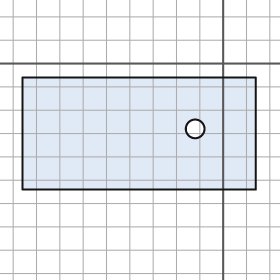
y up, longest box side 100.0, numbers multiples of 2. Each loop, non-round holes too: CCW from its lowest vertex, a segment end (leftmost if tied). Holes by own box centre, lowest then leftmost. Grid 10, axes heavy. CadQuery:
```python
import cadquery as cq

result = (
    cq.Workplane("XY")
    .moveTo(-86.0, -54.0)
    .lineTo(14.0, -54.0)
    .lineTo(14.0, -6.0)
    .lineTo(-86.0, -6.0)
    .close()
    .moveTo(-12.0, -28.0)
    .circle(4.0)
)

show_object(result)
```